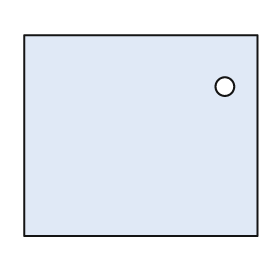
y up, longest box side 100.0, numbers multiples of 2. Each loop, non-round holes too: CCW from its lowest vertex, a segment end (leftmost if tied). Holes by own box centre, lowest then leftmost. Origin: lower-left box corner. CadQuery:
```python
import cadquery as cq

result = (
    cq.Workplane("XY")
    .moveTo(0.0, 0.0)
    .lineTo(100.0, 0.0)
    .lineTo(100.0, 86.0)
    .lineTo(0.0, 86.0)
    .close()
    .moveTo(86.0, 64.0)
    .circle(4.0)
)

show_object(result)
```